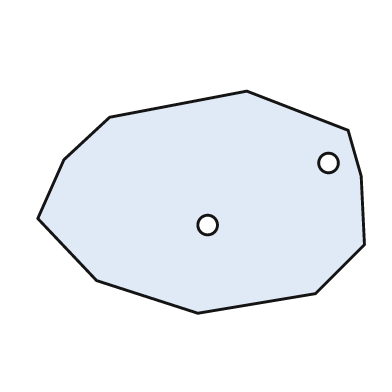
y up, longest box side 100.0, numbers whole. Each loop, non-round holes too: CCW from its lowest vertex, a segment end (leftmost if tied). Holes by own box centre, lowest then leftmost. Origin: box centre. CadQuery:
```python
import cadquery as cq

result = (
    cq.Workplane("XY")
    .moveTo(-1.0, -34.0)
    .lineTo(35.0, -28.0)
    .lineTo(50.0, -13.0)
    .lineTo(49.0, 8.0)
    .lineTo(45.0, 22.0)
    .lineTo(14.0, 34.0)
    .lineTo(-28.0, 26.0)
    .lineTo(-42.0, 13.0)
    .lineTo(-50.0, -5.0)
    .lineTo(-32.0, -24.0)
    .close()
    .moveTo(2.0, -7.0)
    .circle(3.0)
    .moveTo(39.0, 12.0)
    .circle(3.0)
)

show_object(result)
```